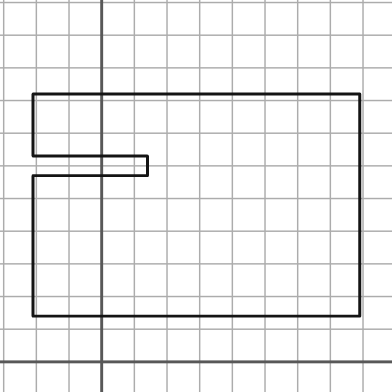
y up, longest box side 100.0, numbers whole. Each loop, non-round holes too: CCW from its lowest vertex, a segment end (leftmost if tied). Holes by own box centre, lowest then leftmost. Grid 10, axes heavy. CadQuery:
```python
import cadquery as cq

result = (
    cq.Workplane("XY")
    .moveTo(-21.0, 14.0)
    .lineTo(79.0, 14.0)
    .lineTo(79.0, 82.0)
    .lineTo(-21.0, 82.0)
    .lineTo(-21.0, 63.0)
    .lineTo(14.0, 63.0)
    .lineTo(14.0, 57.0)
    .lineTo(-21.0, 57.0)
    .close()
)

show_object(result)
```